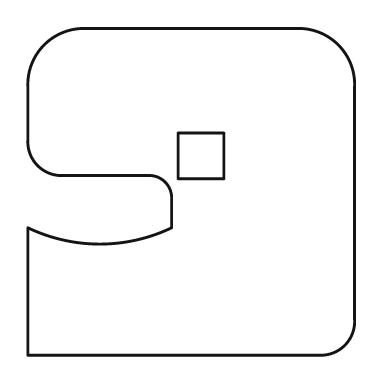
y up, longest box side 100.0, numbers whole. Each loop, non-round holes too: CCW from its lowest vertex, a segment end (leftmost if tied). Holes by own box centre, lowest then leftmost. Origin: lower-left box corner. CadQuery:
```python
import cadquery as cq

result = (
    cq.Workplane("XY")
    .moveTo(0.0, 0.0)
    .lineTo(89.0, 0.0)
    .threePointArc((97.0, 3.0), (100.0, 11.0))
    .lineTo(100.0, 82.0)
    .threePointArc((95.0, 95.0), (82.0, 100.0))
    .lineTo(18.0, 100.0)
    .threePointArc((5.0, 95.0), (0.0, 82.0))
    .lineTo(0.0, 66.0)
    .threePointArc((3.0, 58.0), (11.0, 55.0))
    .lineTo(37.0, 55.0)
    .threePointArc((42.0, 53.0), (44.0, 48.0))
    .lineTo(44.0, 39.0)
    .threePointArc((22.0, 34.0), (0.0, 39.0))
    .close()
    .moveTo(46.0, 54.0)
    .lineTo(60.0, 54.0)
    .lineTo(60.0, 68.0)
    .lineTo(46.0, 68.0)
    .close()
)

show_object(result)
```